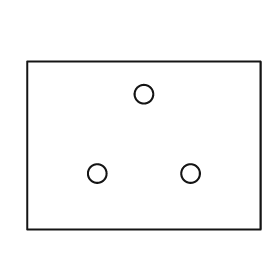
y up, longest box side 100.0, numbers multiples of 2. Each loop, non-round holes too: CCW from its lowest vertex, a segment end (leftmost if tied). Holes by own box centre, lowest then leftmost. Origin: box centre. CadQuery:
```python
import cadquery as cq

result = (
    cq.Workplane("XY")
    .moveTo(-50.0, -36.0)
    .lineTo(50.0, -36.0)
    .lineTo(50.0, 36.0)
    .lineTo(-50.0, 36.0)
    .close()
    .moveTo(-20.0, -12.0)
    .circle(4.0)
    .moveTo(20.0, -12.0)
    .circle(4.0)
    .moveTo(0.0, 22.0)
    .circle(4.0)
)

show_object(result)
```